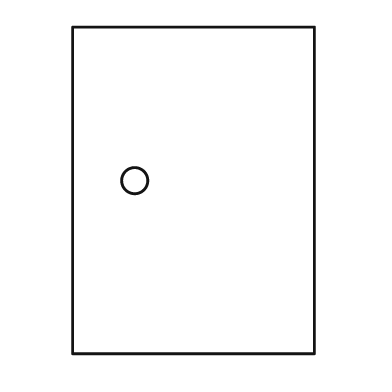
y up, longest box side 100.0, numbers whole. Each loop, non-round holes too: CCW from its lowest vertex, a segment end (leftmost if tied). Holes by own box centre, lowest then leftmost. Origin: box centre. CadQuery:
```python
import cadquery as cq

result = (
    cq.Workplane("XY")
    .moveTo(-37.0, -50.0)
    .lineTo(37.0, -50.0)
    .lineTo(37.0, 50.0)
    .lineTo(-37.0, 50.0)
    .close()
    .moveTo(-18.0, 3.0)
    .circle(4.0)
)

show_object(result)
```